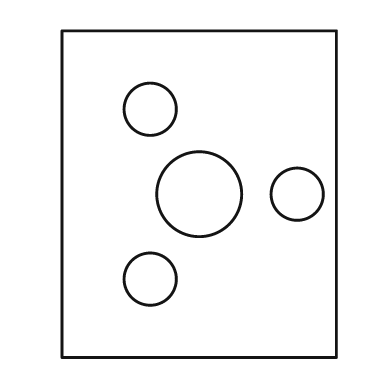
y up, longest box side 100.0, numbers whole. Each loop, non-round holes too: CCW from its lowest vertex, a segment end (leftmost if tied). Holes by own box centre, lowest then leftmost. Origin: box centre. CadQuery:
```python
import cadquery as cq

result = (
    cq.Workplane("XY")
    .moveTo(-42.0, -50.0)
    .lineTo(42.0, -50.0)
    .lineTo(42.0, 50.0)
    .lineTo(-42.0, 50.0)
    .close()
    .moveTo(-15.0, -26.0)
    .circle(8.0)
    .moveTo(0.0, 0.0)
    .circle(13.0)
    .moveTo(30.0, 0.0)
    .circle(8.0)
    .moveTo(-15.0, 26.0)
    .circle(8.0)
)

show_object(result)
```